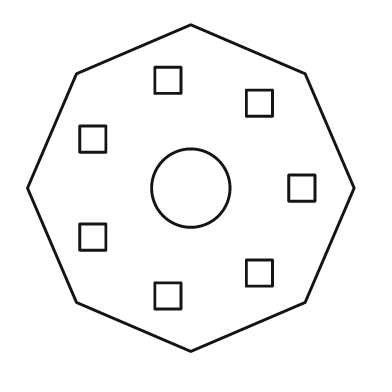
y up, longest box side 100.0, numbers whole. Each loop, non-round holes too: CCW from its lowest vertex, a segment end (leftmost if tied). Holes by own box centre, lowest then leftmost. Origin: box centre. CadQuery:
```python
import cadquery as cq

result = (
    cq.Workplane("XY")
    .moveTo(0.0, -50.0)
    .lineTo(35.0, -35.0)
    .lineTo(50.0, 0.0)
    .lineTo(35.0, 35.0)
    .lineTo(0.0, 50.0)
    .lineTo(-35.0, 35.0)
    .lineTo(-50.0, 0.0)
    .lineTo(-35.0, -35.0)
    .close()
    .moveTo(-11.0, -37.0)
    .lineTo(-3.0, -37.0)
    .lineTo(-3.0, -29.0)
    .lineTo(-11.0, -29.0)
    .close()
    .moveTo(17.0, -30.0)
    .lineTo(25.0, -30.0)
    .lineTo(25.0, -22.0)
    .lineTo(17.0, -22.0)
    .close()
    .moveTo(-34.0, -19.0)
    .lineTo(-26.0, -19.0)
    .lineTo(-26.0, -11.0)
    .lineTo(-34.0, -11.0)
    .close()
    .moveTo(0.0, 0.0)
    .circle(12.0)
    .moveTo(30.0, -4.0)
    .lineTo(38.0, -4.0)
    .lineTo(38.0, 4.0)
    .lineTo(30.0, 4.0)
    .close()
    .moveTo(-34.0, 11.0)
    .lineTo(-26.0, 11.0)
    .lineTo(-26.0, 19.0)
    .lineTo(-34.0, 19.0)
    .close()
    .moveTo(17.0, 22.0)
    .lineTo(25.0, 22.0)
    .lineTo(25.0, 30.0)
    .lineTo(17.0, 30.0)
    .close()
    .moveTo(-11.0, 29.0)
    .lineTo(-3.0, 29.0)
    .lineTo(-3.0, 37.0)
    .lineTo(-11.0, 37.0)
    .close()
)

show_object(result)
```